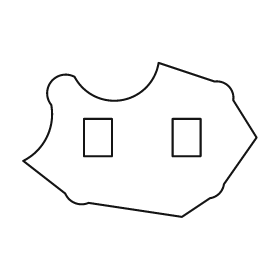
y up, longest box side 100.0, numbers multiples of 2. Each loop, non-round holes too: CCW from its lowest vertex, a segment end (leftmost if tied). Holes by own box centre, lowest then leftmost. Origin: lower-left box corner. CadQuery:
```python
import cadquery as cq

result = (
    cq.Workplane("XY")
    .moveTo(68.0, 0.0)
    .lineTo(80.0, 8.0)
    .threePointArc((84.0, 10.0), (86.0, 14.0))
    .lineTo(100.0, 34.0)
    .lineTo(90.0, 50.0)
    .threePointArc((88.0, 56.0), (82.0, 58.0))
    .lineTo(58.0, 66.0)
    .threePointArc((42.0, 50.0), (22.0, 60.0))
    .threePointArc((12.0, 58.0), (12.0, 48.0))
    .threePointArc((10.0, 34.0), (0.0, 24.0))
    .lineTo(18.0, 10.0)
    .threePointArc((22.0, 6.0), (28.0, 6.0))
    .close()
    .moveTo(26.0, 26.0)
    .lineTo(38.0, 26.0)
    .lineTo(38.0, 42.0)
    .lineTo(26.0, 42.0)
    .close()
    .moveTo(64.0, 26.0)
    .lineTo(76.0, 26.0)
    .lineTo(76.0, 42.0)
    .lineTo(64.0, 42.0)
    .close()
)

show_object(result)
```